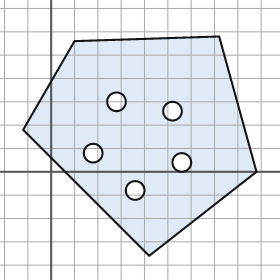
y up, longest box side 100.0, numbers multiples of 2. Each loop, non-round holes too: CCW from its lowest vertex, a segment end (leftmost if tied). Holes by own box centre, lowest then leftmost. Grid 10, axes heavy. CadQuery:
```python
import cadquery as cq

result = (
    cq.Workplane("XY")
    .moveTo(42.0, -36.0)
    .lineTo(88.0, 0.0)
    .lineTo(72.0, 58.0)
    .lineTo(10.0, 56.0)
    .lineTo(-12.0, 18.0)
    .close()
    .moveTo(36.0, -8.0)
    .circle(4.0)
    .moveTo(56.0, 4.0)
    .circle(4.0)
    .moveTo(18.0, 8.0)
    .circle(4.0)
    .moveTo(52.0, 26.0)
    .circle(4.0)
    .moveTo(28.0, 30.0)
    .circle(4.0)
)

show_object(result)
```